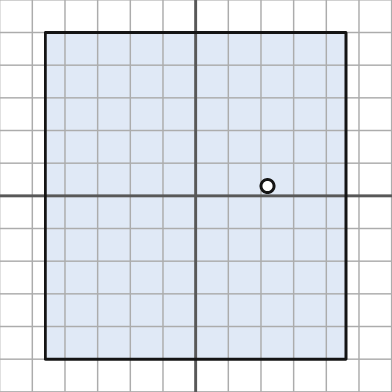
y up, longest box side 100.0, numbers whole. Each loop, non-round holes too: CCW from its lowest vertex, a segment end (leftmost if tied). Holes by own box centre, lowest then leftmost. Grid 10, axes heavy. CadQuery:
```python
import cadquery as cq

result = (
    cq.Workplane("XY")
    .moveTo(-46.0, -50.0)
    .lineTo(46.0, -50.0)
    .lineTo(46.0, 50.0)
    .lineTo(-46.0, 50.0)
    .close()
    .moveTo(22.0, 3.0)
    .circle(2.0)
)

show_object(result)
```